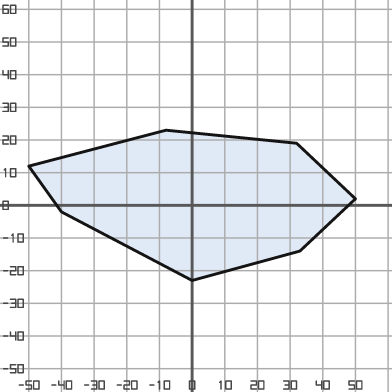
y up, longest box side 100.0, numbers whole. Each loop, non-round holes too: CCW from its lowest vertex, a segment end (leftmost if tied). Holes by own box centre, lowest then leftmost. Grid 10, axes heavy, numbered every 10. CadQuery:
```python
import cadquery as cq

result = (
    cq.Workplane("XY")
    .moveTo(0.0, -23.0)
    .lineTo(33.0, -14.0)
    .lineTo(50.0, 2.0)
    .lineTo(32.0, 19.0)
    .lineTo(-8.0, 23.0)
    .lineTo(-50.0, 12.0)
    .lineTo(-40.0, -2.0)
    .close()
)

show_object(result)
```